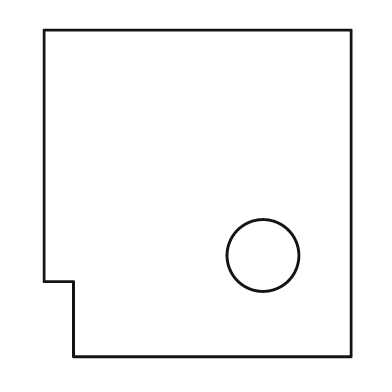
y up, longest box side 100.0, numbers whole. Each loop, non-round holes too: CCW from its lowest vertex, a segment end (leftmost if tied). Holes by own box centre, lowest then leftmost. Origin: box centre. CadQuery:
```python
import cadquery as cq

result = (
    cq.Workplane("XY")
    .moveTo(-38.0, -50.0)
    .lineTo(47.0, -50.0)
    .lineTo(47.0, 50.0)
    .lineTo(-47.0, 50.0)
    .lineTo(-47.0, -27.0)
    .lineTo(-38.0, -27.0)
    .close()
    .moveTo(20.0, -19.0)
    .circle(11.0)
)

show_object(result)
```